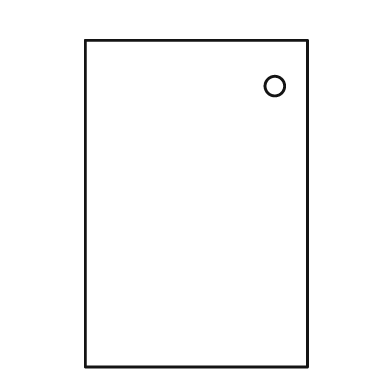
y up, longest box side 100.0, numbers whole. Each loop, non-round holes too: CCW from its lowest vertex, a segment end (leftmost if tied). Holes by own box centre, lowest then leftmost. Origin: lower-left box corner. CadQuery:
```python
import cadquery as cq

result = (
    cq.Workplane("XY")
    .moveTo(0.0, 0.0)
    .lineTo(68.0, 0.0)
    .lineTo(68.0, 100.0)
    .lineTo(0.0, 100.0)
    .close()
    .moveTo(58.0, 86.0)
    .circle(3.0)
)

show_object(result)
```